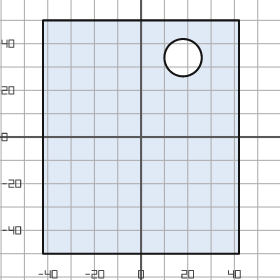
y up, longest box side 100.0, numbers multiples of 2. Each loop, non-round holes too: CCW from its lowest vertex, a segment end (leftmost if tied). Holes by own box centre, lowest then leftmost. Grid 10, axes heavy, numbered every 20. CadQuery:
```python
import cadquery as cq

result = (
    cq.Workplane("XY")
    .moveTo(-42.0, -50.0)
    .lineTo(42.0, -50.0)
    .lineTo(42.0, 50.0)
    .lineTo(-42.0, 50.0)
    .close()
    .moveTo(18.0, 34.0)
    .circle(8.0)
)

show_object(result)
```